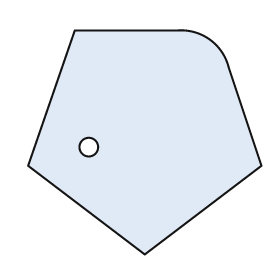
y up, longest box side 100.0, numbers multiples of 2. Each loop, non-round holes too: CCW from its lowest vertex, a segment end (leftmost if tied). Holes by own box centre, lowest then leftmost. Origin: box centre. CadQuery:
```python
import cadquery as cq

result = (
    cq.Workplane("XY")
    .moveTo(0.0, -48.0)
    .lineTo(50.0, -10.0)
    .lineTo(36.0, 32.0)
    .threePointArc((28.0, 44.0), (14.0, 48.0))
    .lineTo(-30.0, 48.0)
    .lineTo(-50.0, -10.0)
    .close()
    .moveTo(-24.0, -2.0)
    .circle(4.0)
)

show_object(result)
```